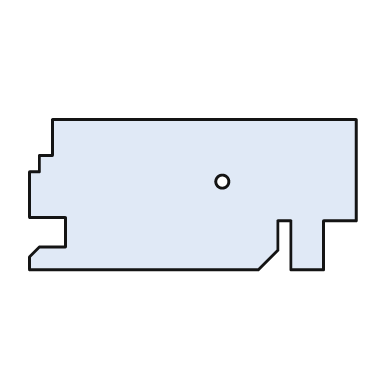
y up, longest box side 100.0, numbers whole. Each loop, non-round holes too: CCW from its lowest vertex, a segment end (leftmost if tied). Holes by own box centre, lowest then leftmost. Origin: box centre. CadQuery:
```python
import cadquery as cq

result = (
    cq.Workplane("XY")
    .moveTo(-50.0, -23.0)
    .lineTo(20.0, -23.0)
    .lineTo(26.0, -17.0)
    .lineTo(26.0, -8.0)
    .lineTo(30.0, -8.0)
    .lineTo(30.0, -23.0)
    .lineTo(40.0, -23.0)
    .lineTo(40.0, -8.0)
    .lineTo(50.0, -8.0)
    .lineTo(50.0, 23.0)
    .lineTo(-43.0, 23.0)
    .lineTo(-43.0, 12.0)
    .lineTo(-47.0, 12.0)
    .lineTo(-47.0, 7.0)
    .lineTo(-50.0, 7.0)
    .lineTo(-50.0, -7.0)
    .lineTo(-39.0, -7.0)
    .lineTo(-39.0, -16.0)
    .lineTo(-47.0, -16.0)
    .lineTo(-50.0, -19.0)
    .close()
    .moveTo(9.0, 4.0)
    .circle(2.0)
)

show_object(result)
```